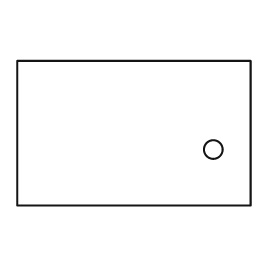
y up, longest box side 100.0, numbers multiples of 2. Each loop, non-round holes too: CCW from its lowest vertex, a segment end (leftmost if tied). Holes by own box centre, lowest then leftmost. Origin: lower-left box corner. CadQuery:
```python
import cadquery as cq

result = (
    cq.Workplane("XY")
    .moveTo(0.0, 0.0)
    .lineTo(100.0, 0.0)
    .lineTo(100.0, 62.0)
    .lineTo(0.0, 62.0)
    .close()
    .moveTo(84.0, 24.0)
    .circle(4.0)
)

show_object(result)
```